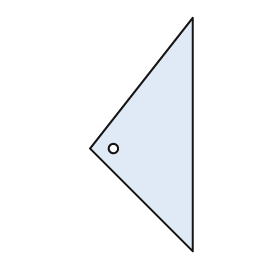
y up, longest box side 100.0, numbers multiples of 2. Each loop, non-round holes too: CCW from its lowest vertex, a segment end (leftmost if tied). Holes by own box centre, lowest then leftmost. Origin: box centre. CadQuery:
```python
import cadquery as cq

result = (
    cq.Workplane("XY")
    .moveTo(22.0, -50.0)
    .lineTo(22.0, 50.0)
    .lineTo(-22.0, -6.0)
    .close()
    .moveTo(-12.0, -6.0)
    .circle(2.0)
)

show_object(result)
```